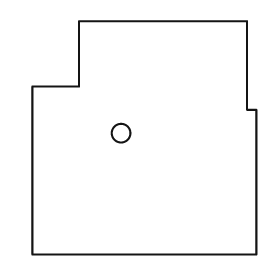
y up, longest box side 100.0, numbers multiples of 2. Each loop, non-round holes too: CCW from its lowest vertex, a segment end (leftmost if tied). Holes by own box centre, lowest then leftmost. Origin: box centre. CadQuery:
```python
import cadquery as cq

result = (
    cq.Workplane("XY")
    .moveTo(-48.0, -50.0)
    .lineTo(48.0, -50.0)
    .lineTo(48.0, 12.0)
    .lineTo(44.0, 12.0)
    .lineTo(44.0, 50.0)
    .lineTo(-28.0, 50.0)
    .lineTo(-28.0, 22.0)
    .lineTo(-48.0, 22.0)
    .close()
    .moveTo(-10.0, 2.0)
    .circle(4.0)
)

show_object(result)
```